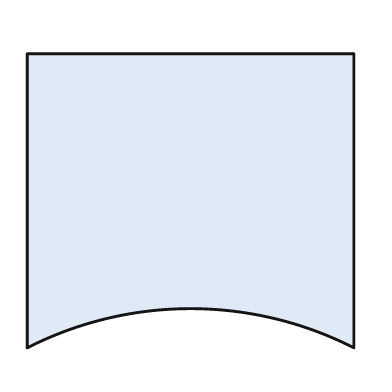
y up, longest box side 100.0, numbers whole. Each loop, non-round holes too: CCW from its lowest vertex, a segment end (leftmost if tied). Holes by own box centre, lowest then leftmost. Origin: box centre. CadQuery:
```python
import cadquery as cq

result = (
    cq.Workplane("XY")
    .moveTo(-50.0, -45.0)
    .threePointArc((0.0, -33.0), (50.0, -45.0))
    .lineTo(50.0, 45.0)
    .lineTo(-50.0, 45.0)
    .close()
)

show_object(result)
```